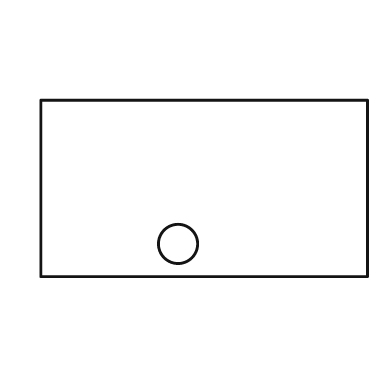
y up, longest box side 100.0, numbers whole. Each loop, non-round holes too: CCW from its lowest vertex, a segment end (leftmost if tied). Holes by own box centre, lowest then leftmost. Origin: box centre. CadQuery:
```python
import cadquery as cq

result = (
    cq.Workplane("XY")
    .moveTo(-50.0, -27.0)
    .lineTo(50.0, -27.0)
    .lineTo(50.0, 27.0)
    .lineTo(-50.0, 27.0)
    .close()
    .moveTo(-8.0, -17.0)
    .circle(6.0)
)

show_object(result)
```